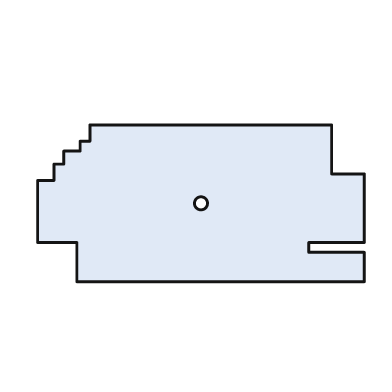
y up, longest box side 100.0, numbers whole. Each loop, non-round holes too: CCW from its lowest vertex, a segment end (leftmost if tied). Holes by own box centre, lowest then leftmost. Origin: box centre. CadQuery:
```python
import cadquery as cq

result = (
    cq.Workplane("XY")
    .moveTo(-38.0, -24.0)
    .lineTo(50.0, -24.0)
    .lineTo(50.0, -15.0)
    .lineTo(33.0, -15.0)
    .lineTo(33.0, -12.0)
    .lineTo(50.0, -12.0)
    .lineTo(50.0, 9.0)
    .lineTo(40.0, 9.0)
    .lineTo(40.0, 24.0)
    .lineTo(-34.0, 24.0)
    .lineTo(-34.0, 19.0)
    .lineTo(-37.0, 19.0)
    .lineTo(-37.0, 16.0)
    .lineTo(-42.0, 16.0)
    .lineTo(-42.0, 12.0)
    .lineTo(-45.0, 12.0)
    .lineTo(-45.0, 7.0)
    .lineTo(-50.0, 7.0)
    .lineTo(-50.0, -12.0)
    .lineTo(-38.0, -12.0)
    .close()
    .moveTo(0.0, 0.0)
    .circle(2.0)
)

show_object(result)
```